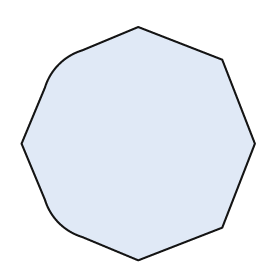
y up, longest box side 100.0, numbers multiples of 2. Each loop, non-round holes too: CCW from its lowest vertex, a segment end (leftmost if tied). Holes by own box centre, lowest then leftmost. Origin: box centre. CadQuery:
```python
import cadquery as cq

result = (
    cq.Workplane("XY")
    .moveTo(0.0, -50.0)
    .lineTo(36.0, -36.0)
    .lineTo(50.0, 0.0)
    .lineTo(36.0, 36.0)
    .lineTo(0.0, 50.0)
    .lineTo(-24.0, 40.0)
    .threePointArc((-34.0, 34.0), (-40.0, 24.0))
    .lineTo(-50.0, 0.0)
    .lineTo(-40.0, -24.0)
    .threePointArc((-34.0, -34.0), (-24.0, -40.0))
    .close()
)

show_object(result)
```